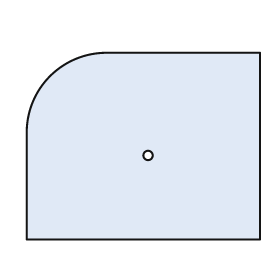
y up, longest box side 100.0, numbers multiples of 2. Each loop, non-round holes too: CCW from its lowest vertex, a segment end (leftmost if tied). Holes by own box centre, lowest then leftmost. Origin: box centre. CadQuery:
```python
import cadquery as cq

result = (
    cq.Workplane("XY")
    .moveTo(-50.0, -40.0)
    .lineTo(50.0, -40.0)
    .lineTo(50.0, 40.0)
    .lineTo(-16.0, 40.0)
    .threePointArc((-40.0, 30.0), (-50.0, 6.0))
    .close()
    .moveTo(2.0, -4.0)
    .circle(2.0)
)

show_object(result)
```